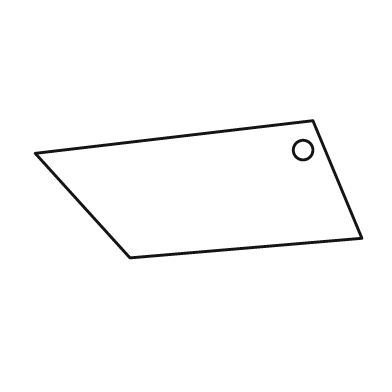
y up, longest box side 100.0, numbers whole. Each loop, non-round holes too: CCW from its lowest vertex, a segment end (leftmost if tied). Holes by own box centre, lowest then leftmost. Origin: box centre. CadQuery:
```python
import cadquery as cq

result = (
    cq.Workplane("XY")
    .moveTo(-21.0, -21.0)
    .lineTo(50.0, -15.0)
    .lineTo(35.0, 21.0)
    .lineTo(-50.0, 11.0)
    .close()
    .moveTo(32.0, 12.0)
    .circle(3.0)
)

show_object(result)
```